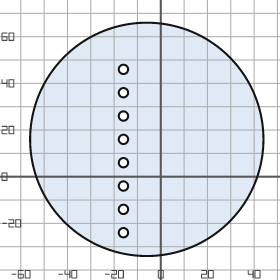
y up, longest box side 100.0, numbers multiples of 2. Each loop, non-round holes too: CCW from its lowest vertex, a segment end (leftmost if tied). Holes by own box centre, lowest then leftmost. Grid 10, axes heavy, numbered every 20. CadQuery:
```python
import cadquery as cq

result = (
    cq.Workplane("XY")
    .moveTo(-6.0, 16.0)
    .circle(50.0)
    .moveTo(-16.0, -24.0)
    .circle(2.0)
    .moveTo(-16.0, -14.0)
    .circle(2.0)
    .moveTo(-16.0, -4.0)
    .circle(2.0)
    .moveTo(-16.0, 6.0)
    .circle(2.0)
    .moveTo(-16.0, 16.0)
    .circle(2.0)
    .moveTo(-16.0, 26.0)
    .circle(2.0)
    .moveTo(-16.0, 36.0)
    .circle(2.0)
    .moveTo(-16.0, 46.0)
    .circle(2.0)
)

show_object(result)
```